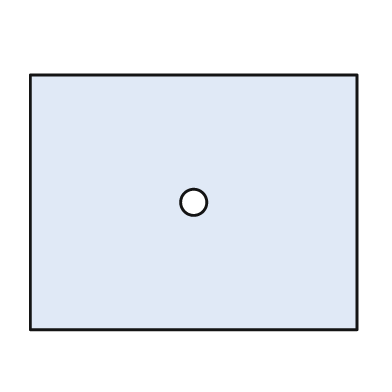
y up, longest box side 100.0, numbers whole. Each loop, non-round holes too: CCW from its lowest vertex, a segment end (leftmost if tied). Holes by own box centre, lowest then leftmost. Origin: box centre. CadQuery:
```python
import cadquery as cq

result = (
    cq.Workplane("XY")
    .moveTo(-50.0, -39.0)
    .lineTo(50.0, -39.0)
    .lineTo(50.0, 39.0)
    .lineTo(-50.0, 39.0)
    .close()
    .moveTo(0.0, 0.0)
    .circle(4.0)
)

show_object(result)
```